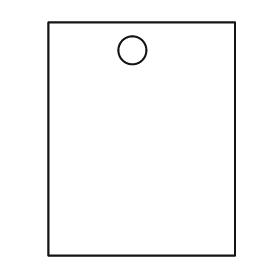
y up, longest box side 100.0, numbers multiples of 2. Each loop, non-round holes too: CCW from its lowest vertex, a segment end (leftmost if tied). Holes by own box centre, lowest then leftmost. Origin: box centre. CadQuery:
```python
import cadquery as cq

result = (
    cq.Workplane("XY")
    .moveTo(-40.0, -50.0)
    .lineTo(40.0, -50.0)
    .lineTo(40.0, 50.0)
    .lineTo(-40.0, 50.0)
    .close()
    .moveTo(-4.0, 38.0)
    .circle(6.0)
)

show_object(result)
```